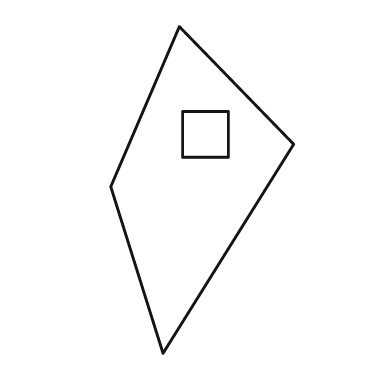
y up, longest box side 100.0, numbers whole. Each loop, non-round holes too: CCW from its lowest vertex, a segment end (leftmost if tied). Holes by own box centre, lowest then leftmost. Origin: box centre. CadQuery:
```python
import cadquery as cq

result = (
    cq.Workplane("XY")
    .moveTo(-12.0, -50.0)
    .lineTo(28.0, 14.0)
    .lineTo(-7.0, 50.0)
    .lineTo(-28.0, 1.0)
    .close()
    .moveTo(-6.0, 10.0)
    .lineTo(8.0, 10.0)
    .lineTo(8.0, 24.0)
    .lineTo(-6.0, 24.0)
    .close()
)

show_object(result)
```